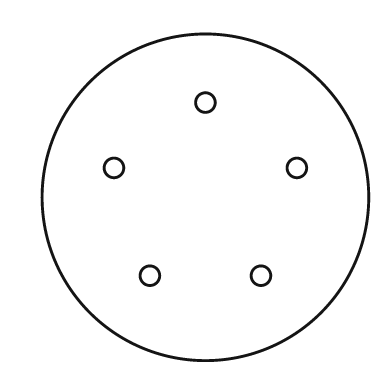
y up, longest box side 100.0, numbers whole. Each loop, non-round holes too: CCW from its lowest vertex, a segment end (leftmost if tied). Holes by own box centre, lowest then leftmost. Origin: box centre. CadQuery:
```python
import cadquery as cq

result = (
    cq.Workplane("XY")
    .moveTo(0.0, 0.0)
    .circle(50.0)
    .moveTo(-17.0, -24.0)
    .circle(3.0)
    .moveTo(17.0, -24.0)
    .circle(3.0)
    .moveTo(-28.0, 9.0)
    .circle(3.0)
    .moveTo(28.0, 9.0)
    .circle(3.0)
    .moveTo(0.0, 29.0)
    .circle(3.0)
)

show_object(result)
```